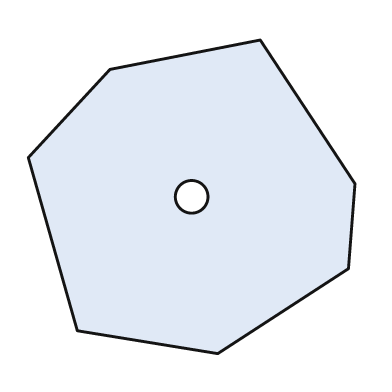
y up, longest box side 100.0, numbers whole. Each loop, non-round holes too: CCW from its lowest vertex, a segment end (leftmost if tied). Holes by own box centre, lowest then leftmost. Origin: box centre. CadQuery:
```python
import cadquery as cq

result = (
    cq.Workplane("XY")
    .moveTo(8.0, -48.0)
    .lineTo(48.0, -22.0)
    .lineTo(50.0, 4.0)
    .lineTo(21.0, 48.0)
    .lineTo(-25.0, 39.0)
    .lineTo(-50.0, 12.0)
    .lineTo(-35.0, -41.0)
    .close()
    .moveTo(0.0, 0.0)
    .circle(5.0)
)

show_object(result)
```